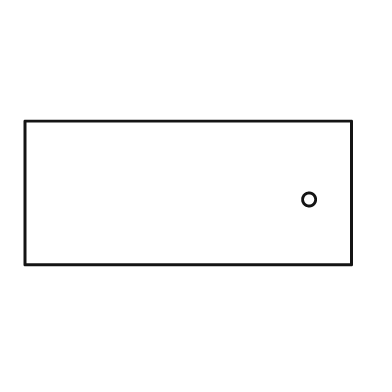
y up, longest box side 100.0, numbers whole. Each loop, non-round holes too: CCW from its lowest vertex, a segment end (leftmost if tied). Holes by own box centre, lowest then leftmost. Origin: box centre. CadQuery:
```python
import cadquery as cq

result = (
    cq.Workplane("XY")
    .moveTo(-50.0, -22.0)
    .lineTo(50.0, -22.0)
    .lineTo(50.0, 22.0)
    .lineTo(-50.0, 22.0)
    .close()
    .moveTo(37.0, -2.0)
    .circle(2.0)
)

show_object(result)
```